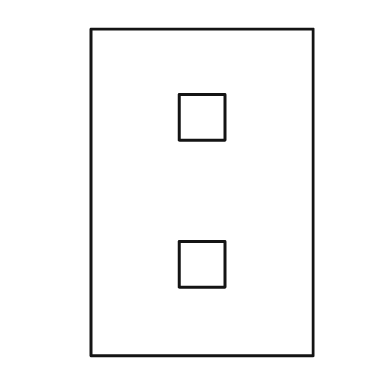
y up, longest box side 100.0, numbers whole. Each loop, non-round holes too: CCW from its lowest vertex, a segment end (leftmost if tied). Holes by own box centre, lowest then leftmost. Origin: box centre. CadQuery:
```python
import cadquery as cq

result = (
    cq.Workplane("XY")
    .moveTo(-34.0, -50.0)
    .lineTo(34.0, -50.0)
    .lineTo(34.0, 50.0)
    .lineTo(-34.0, 50.0)
    .close()
    .moveTo(-7.0, -29.0)
    .lineTo(7.0, -29.0)
    .lineTo(7.0, -15.0)
    .lineTo(-7.0, -15.0)
    .close()
    .moveTo(-7.0, 16.0)
    .lineTo(7.0, 16.0)
    .lineTo(7.0, 30.0)
    .lineTo(-7.0, 30.0)
    .close()
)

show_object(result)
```